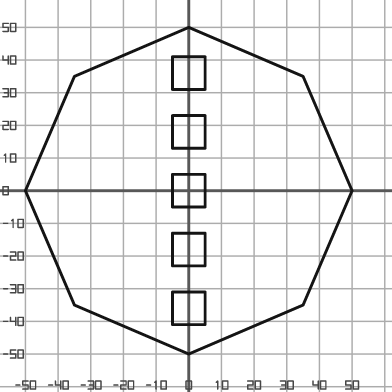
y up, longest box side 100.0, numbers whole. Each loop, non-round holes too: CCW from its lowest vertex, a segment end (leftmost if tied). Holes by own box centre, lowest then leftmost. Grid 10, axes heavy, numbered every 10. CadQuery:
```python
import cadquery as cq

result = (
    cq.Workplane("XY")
    .moveTo(0.0, -50.0)
    .lineTo(35.0, -35.0)
    .lineTo(50.0, 0.0)
    .lineTo(35.0, 35.0)
    .lineTo(0.0, 50.0)
    .lineTo(-35.0, 35.0)
    .lineTo(-50.0, 0.0)
    .lineTo(-35.0, -35.0)
    .close()
    .moveTo(-5.0, -41.0)
    .lineTo(5.0, -41.0)
    .lineTo(5.0, -31.0)
    .lineTo(-5.0, -31.0)
    .close()
    .moveTo(-5.0, -23.0)
    .lineTo(5.0, -23.0)
    .lineTo(5.0, -13.0)
    .lineTo(-5.0, -13.0)
    .close()
    .moveTo(-5.0, -5.0)
    .lineTo(5.0, -5.0)
    .lineTo(5.0, 5.0)
    .lineTo(-5.0, 5.0)
    .close()
    .moveTo(-5.0, 13.0)
    .lineTo(5.0, 13.0)
    .lineTo(5.0, 23.0)
    .lineTo(-5.0, 23.0)
    .close()
    .moveTo(-5.0, 31.0)
    .lineTo(5.0, 31.0)
    .lineTo(5.0, 41.0)
    .lineTo(-5.0, 41.0)
    .close()
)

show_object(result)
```